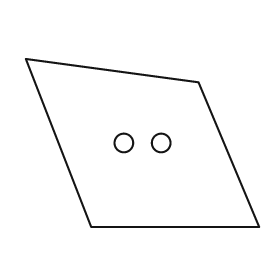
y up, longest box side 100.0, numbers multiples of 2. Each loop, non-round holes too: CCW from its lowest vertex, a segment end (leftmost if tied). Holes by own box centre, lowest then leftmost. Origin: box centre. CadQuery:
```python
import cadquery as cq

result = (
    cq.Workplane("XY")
    .moveTo(-22.0, -36.0)
    .lineTo(50.0, -36.0)
    .lineTo(24.0, 26.0)
    .lineTo(-50.0, 36.0)
    .close()
    .moveTo(-8.0, 0.0)
    .circle(4.0)
    .moveTo(8.0, 0.0)
    .circle(4.0)
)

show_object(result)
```